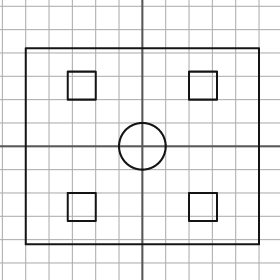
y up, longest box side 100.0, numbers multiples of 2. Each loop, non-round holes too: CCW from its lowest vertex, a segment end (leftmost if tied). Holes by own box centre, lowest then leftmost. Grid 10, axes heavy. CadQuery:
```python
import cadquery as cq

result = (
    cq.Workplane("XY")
    .moveTo(-50.0, -42.0)
    .lineTo(50.0, -42.0)
    .lineTo(50.0, 42.0)
    .lineTo(-50.0, 42.0)
    .close()
    .moveTo(-32.0, -32.0)
    .lineTo(-20.0, -32.0)
    .lineTo(-20.0, -20.0)
    .lineTo(-32.0, -20.0)
    .close()
    .moveTo(20.0, -32.0)
    .lineTo(32.0, -32.0)
    .lineTo(32.0, -20.0)
    .lineTo(20.0, -20.0)
    .close()
    .moveTo(0.0, 0.0)
    .circle(10.0)
    .moveTo(-32.0, 20.0)
    .lineTo(-20.0, 20.0)
    .lineTo(-20.0, 32.0)
    .lineTo(-32.0, 32.0)
    .close()
    .moveTo(20.0, 20.0)
    .lineTo(32.0, 20.0)
    .lineTo(32.0, 32.0)
    .lineTo(20.0, 32.0)
    .close()
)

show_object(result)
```